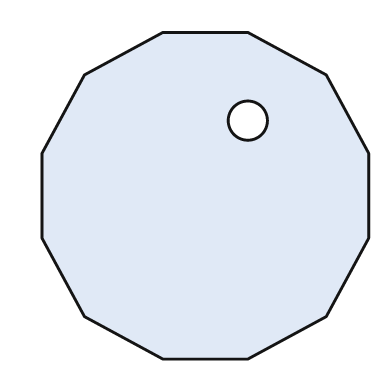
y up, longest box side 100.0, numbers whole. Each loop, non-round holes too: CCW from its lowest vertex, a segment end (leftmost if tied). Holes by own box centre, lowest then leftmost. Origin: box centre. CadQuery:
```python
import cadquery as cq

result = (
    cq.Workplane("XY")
    .moveTo(-13.0, -50.0)
    .lineTo(13.0, -50.0)
    .lineTo(37.0, -37.0)
    .lineTo(50.0, -13.0)
    .lineTo(50.0, 13.0)
    .lineTo(37.0, 37.0)
    .lineTo(13.0, 50.0)
    .lineTo(-13.0, 50.0)
    .lineTo(-37.0, 37.0)
    .lineTo(-50.0, 13.0)
    .lineTo(-50.0, -13.0)
    .lineTo(-37.0, -37.0)
    .close()
    .moveTo(13.0, 23.0)
    .circle(6.0)
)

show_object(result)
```